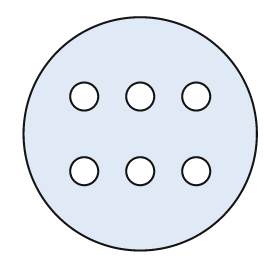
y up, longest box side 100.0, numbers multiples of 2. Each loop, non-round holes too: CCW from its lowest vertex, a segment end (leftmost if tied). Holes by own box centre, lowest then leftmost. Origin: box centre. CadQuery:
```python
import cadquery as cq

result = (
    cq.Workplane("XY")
    .moveTo(0.0, 0.0)
    .circle(50.0)
    .moveTo(-24.0, -16.0)
    .circle(6.0)
    .moveTo(0.0, -16.0)
    .circle(6.0)
    .moveTo(24.0, -16.0)
    .circle(6.0)
    .moveTo(-24.0, 16.0)
    .circle(6.0)
    .moveTo(0.0, 16.0)
    .circle(6.0)
    .moveTo(24.0, 16.0)
    .circle(6.0)
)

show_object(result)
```